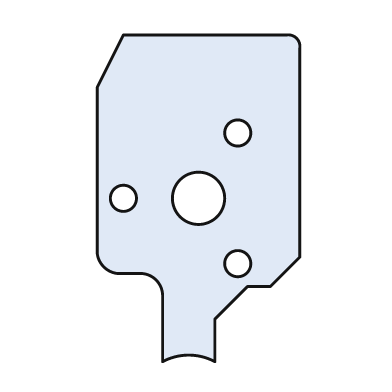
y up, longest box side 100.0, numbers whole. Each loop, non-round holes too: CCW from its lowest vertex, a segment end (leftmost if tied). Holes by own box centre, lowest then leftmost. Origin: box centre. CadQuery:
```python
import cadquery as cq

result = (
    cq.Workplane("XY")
    .moveTo(-11.0, -50.0)
    .threePointArc((-3.0, -48.0), (5.0, -50.0))
    .lineTo(5.0, -37.0)
    .lineTo(15.0, -27.0)
    .lineTo(22.0, -27.0)
    .lineTo(31.0, -18.0)
    .lineTo(31.0, 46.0)
    .threePointArc((30.0, 49.0), (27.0, 50.0))
    .lineTo(-23.0, 50.0)
    .lineTo(-31.0, 34.0)
    .lineTo(-31.0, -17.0)
    .threePointArc((-29.0, -21.0), (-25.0, -23.0))
    .lineTo(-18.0, -23.0)
    .threePointArc((-13.0, -25.0), (-11.0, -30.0))
    .close()
    .moveTo(12.0, -20.0)
    .circle(4.0)
    .moveTo(-23.0, 0.0)
    .circle(4.0)
    .moveTo(0.0, 0.0)
    .circle(8.0)
    .moveTo(12.0, 20.0)
    .circle(4.0)
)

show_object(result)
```